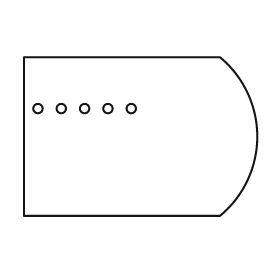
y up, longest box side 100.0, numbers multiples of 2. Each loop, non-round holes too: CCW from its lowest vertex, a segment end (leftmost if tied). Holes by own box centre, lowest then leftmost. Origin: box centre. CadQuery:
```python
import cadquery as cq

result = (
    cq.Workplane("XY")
    .moveTo(-50.0, -34.0)
    .lineTo(34.0, -34.0)
    .threePointArc((50.0, 0.0), (34.0, 34.0))
    .lineTo(-50.0, 34.0)
    .close()
    .moveTo(-44.0, 12.0)
    .circle(2.0)
    .moveTo(-34.0, 12.0)
    .circle(2.0)
    .moveTo(-24.0, 12.0)
    .circle(2.0)
    .moveTo(-14.0, 12.0)
    .circle(2.0)
    .moveTo(-4.0, 12.0)
    .circle(2.0)
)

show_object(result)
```